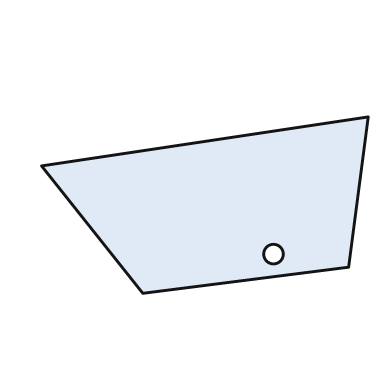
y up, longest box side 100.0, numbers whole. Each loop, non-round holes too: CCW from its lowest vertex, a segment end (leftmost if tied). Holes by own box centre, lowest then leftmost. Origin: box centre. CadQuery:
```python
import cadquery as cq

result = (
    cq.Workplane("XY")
    .moveTo(-19.0, -27.0)
    .lineTo(44.0, -19.0)
    .lineTo(50.0, 27.0)
    .lineTo(-50.0, 12.0)
    .close()
    .moveTo(21.0, -15.0)
    .circle(3.0)
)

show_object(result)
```